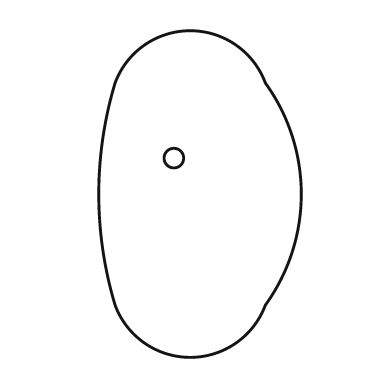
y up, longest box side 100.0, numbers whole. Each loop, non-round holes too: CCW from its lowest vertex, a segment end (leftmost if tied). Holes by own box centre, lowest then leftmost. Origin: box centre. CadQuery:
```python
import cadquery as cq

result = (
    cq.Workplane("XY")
    .moveTo(-26.0, -34.0)
    .threePointArc((-3.0, -50.0), (20.0, -34.0))
    .threePointArc((31.0, 0.0), (20.0, 34.0))
    .threePointArc((-3.0, 50.0), (-26.0, 34.0))
    .threePointArc((-31.0, 0.0), (-26.0, -34.0))
    .close()
    .moveTo(-8.0, 11.0)
    .circle(3.0)
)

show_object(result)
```